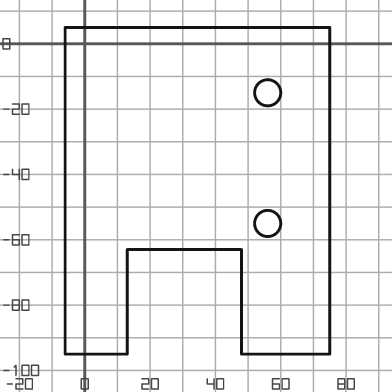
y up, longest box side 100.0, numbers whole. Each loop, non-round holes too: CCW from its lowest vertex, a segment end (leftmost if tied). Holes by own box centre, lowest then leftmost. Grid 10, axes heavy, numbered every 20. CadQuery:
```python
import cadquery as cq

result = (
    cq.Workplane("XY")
    .moveTo(-6.0, -95.0)
    .lineTo(13.0, -95.0)
    .lineTo(13.0, -63.0)
    .lineTo(48.0, -63.0)
    .lineTo(48.0, -95.0)
    .lineTo(75.0, -95.0)
    .lineTo(75.0, 5.0)
    .lineTo(-6.0, 5.0)
    .close()
    .moveTo(56.0, -55.0)
    .circle(4.0)
    .moveTo(56.0, -15.0)
    .circle(4.0)
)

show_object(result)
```